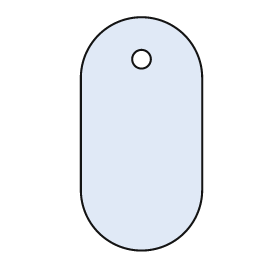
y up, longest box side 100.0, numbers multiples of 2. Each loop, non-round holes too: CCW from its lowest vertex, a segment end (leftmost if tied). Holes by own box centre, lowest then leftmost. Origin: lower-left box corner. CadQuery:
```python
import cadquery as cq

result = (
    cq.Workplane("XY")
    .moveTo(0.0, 26.0)
    .threePointArc((26.0, 0.0), (52.0, 26.0))
    .lineTo(52.0, 74.0)
    .threePointArc((26.0, 100.0), (0.0, 74.0))
    .close()
    .moveTo(26.0, 82.0)
    .circle(4.0)
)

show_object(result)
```